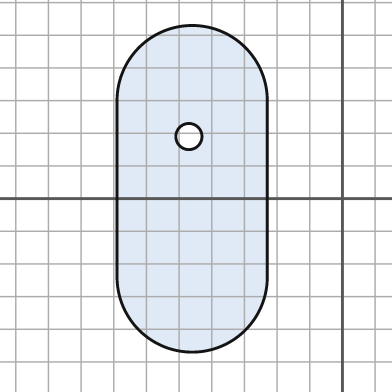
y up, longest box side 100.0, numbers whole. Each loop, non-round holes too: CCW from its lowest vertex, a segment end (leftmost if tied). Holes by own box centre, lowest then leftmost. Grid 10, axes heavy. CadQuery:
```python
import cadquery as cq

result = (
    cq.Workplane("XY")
    .moveTo(-69.0, -24.0)
    .threePointArc((-46.0, -47.0), (-23.0, -24.0))
    .lineTo(-23.0, 30.0)
    .threePointArc((-46.0, 53.0), (-69.0, 30.0))
    .close()
    .moveTo(-47.0, 19.0)
    .circle(4.0)
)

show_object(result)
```